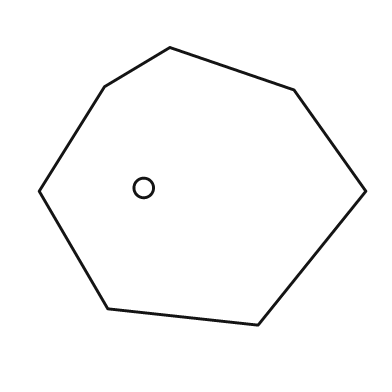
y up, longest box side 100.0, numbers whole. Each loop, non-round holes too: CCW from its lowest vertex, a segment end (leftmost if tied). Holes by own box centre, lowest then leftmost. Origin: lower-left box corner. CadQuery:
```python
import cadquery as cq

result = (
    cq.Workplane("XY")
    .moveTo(67.0, 0.0)
    .lineTo(100.0, 41.0)
    .lineTo(78.0, 72.0)
    .lineTo(40.0, 85.0)
    .lineTo(20.0, 73.0)
    .lineTo(0.0, 41.0)
    .lineTo(21.0, 5.0)
    .close()
    .moveTo(32.0, 42.0)
    .circle(3.0)
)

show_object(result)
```